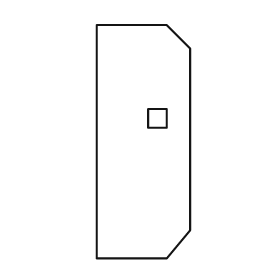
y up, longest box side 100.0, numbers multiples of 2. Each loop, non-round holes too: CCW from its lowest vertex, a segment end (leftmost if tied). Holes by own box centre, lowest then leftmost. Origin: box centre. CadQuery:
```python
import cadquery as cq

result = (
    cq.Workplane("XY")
    .moveTo(-20.0, -50.0)
    .lineTo(10.0, -50.0)
    .lineTo(20.0, -38.0)
    .lineTo(20.0, 40.0)
    .lineTo(10.0, 50.0)
    .lineTo(-20.0, 50.0)
    .close()
    .moveTo(2.0, 6.0)
    .lineTo(10.0, 6.0)
    .lineTo(10.0, 14.0)
    .lineTo(2.0, 14.0)
    .close()
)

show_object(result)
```